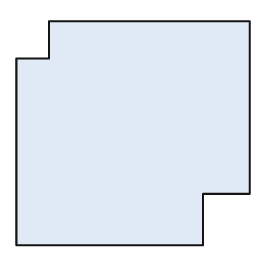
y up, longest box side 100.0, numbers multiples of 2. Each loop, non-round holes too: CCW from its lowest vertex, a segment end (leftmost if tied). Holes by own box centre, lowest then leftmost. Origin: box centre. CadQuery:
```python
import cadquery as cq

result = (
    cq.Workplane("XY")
    .moveTo(-50.0, -48.0)
    .lineTo(30.0, -48.0)
    .lineTo(30.0, -26.0)
    .lineTo(50.0, -26.0)
    .lineTo(50.0, 48.0)
    .lineTo(-36.0, 48.0)
    .lineTo(-36.0, 32.0)
    .lineTo(-50.0, 32.0)
    .close()
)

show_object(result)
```